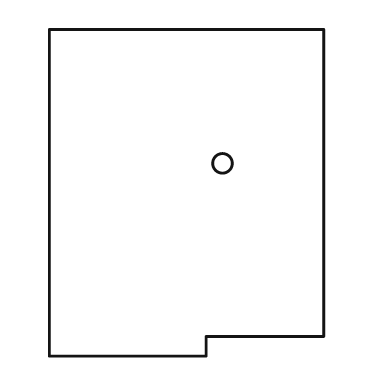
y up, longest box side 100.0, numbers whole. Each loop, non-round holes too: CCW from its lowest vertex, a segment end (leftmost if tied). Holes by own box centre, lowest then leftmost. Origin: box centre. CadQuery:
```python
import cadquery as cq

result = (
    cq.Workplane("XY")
    .moveTo(-42.0, -50.0)
    .lineTo(6.0, -50.0)
    .lineTo(6.0, -44.0)
    .lineTo(42.0, -44.0)
    .lineTo(42.0, 50.0)
    .lineTo(-42.0, 50.0)
    .close()
    .moveTo(11.0, 9.0)
    .circle(3.0)
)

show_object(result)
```